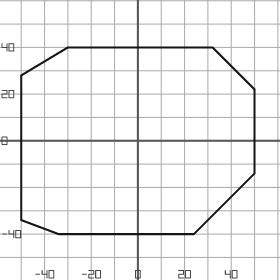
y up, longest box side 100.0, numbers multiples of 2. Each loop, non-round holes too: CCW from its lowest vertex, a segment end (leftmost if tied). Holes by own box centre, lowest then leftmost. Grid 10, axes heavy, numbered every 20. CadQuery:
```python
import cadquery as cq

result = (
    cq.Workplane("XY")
    .moveTo(-34.0, -40.0)
    .lineTo(24.0, -40.0)
    .lineTo(50.0, -14.0)
    .lineTo(50.0, 22.0)
    .lineTo(32.0, 40.0)
    .lineTo(-30.0, 40.0)
    .lineTo(-50.0, 28.0)
    .lineTo(-50.0, -34.0)
    .close()
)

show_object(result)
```